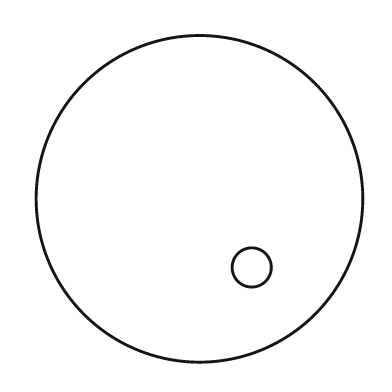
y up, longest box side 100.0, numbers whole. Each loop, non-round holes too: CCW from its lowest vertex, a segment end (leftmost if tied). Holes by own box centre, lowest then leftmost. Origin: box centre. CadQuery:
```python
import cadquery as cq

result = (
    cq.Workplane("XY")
    .moveTo(0.0, 0.0)
    .circle(50.0)
    .moveTo(16.0, -21.0)
    .circle(6.0)
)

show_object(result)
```